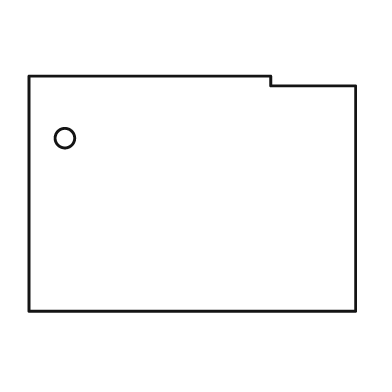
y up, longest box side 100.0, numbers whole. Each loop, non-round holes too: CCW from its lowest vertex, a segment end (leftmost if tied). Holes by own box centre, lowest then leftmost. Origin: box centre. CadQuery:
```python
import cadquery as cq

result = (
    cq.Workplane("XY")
    .moveTo(-50.0, -36.0)
    .lineTo(50.0, -36.0)
    .lineTo(50.0, 33.0)
    .lineTo(24.0, 33.0)
    .lineTo(24.0, 36.0)
    .lineTo(-50.0, 36.0)
    .close()
    .moveTo(-39.0, 17.0)
    .circle(3.0)
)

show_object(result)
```